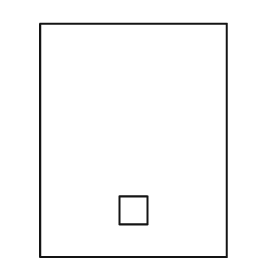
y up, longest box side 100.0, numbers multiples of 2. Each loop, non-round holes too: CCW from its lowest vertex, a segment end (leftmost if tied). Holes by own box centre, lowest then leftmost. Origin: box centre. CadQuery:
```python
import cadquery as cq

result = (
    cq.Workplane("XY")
    .moveTo(-40.0, -50.0)
    .lineTo(40.0, -50.0)
    .lineTo(40.0, 50.0)
    .lineTo(-40.0, 50.0)
    .close()
    .moveTo(-6.0, -36.0)
    .lineTo(6.0, -36.0)
    .lineTo(6.0, -24.0)
    .lineTo(-6.0, -24.0)
    .close()
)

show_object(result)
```